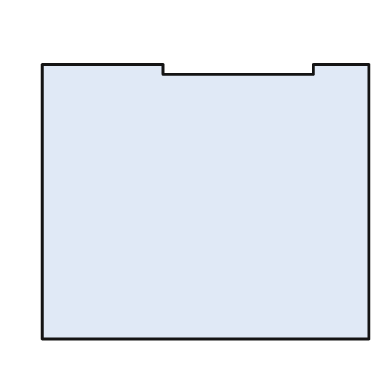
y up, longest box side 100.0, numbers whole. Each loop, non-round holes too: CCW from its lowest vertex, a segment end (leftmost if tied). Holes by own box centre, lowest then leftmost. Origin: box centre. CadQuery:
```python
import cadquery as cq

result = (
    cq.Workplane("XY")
    .moveTo(-50.0, -42.0)
    .lineTo(50.0, -42.0)
    .lineTo(50.0, 42.0)
    .lineTo(33.0, 42.0)
    .lineTo(33.0, 39.0)
    .lineTo(-13.0, 39.0)
    .lineTo(-13.0, 42.0)
    .lineTo(-50.0, 42.0)
    .close()
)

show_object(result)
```